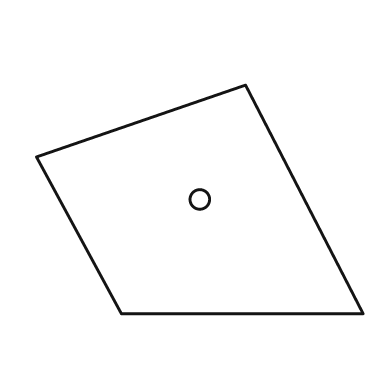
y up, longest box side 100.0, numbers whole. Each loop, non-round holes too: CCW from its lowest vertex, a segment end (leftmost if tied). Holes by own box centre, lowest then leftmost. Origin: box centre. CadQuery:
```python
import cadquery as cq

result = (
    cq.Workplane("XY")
    .moveTo(-24.0, -35.0)
    .lineTo(50.0, -35.0)
    .lineTo(14.0, 35.0)
    .lineTo(-50.0, 13.0)
    .close()
    .moveTo(0.0, 0.0)
    .circle(3.0)
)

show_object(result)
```